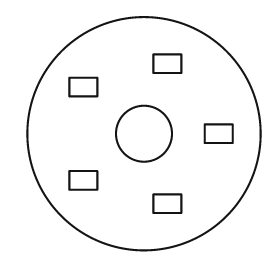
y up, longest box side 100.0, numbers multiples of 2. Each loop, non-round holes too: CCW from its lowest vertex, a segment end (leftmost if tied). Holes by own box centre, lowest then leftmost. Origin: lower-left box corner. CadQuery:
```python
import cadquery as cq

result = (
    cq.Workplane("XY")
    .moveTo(50.0, 50.0)
    .circle(50.0)
    .moveTo(54.0, 16.0)
    .lineTo(66.0, 16.0)
    .lineTo(66.0, 24.0)
    .lineTo(54.0, 24.0)
    .close()
    .moveTo(18.0, 26.0)
    .lineTo(30.0, 26.0)
    .lineTo(30.0, 34.0)
    .lineTo(18.0, 34.0)
    .close()
    .moveTo(50.0, 50.0)
    .circle(12.0)
    .moveTo(76.0, 46.0)
    .lineTo(88.0, 46.0)
    .lineTo(88.0, 54.0)
    .lineTo(76.0, 54.0)
    .close()
    .moveTo(18.0, 66.0)
    .lineTo(30.0, 66.0)
    .lineTo(30.0, 74.0)
    .lineTo(18.0, 74.0)
    .close()
    .moveTo(54.0, 76.0)
    .lineTo(66.0, 76.0)
    .lineTo(66.0, 84.0)
    .lineTo(54.0, 84.0)
    .close()
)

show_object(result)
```